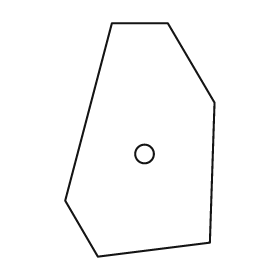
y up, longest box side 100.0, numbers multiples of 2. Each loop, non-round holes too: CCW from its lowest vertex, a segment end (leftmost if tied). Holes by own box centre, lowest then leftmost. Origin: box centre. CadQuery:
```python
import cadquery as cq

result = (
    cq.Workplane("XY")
    .moveTo(-18.0, -50.0)
    .lineTo(30.0, -44.0)
    .lineTo(32.0, 16.0)
    .lineTo(12.0, 50.0)
    .lineTo(-12.0, 50.0)
    .lineTo(-32.0, -26.0)
    .close()
    .moveTo(2.0, -6.0)
    .circle(4.0)
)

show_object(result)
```